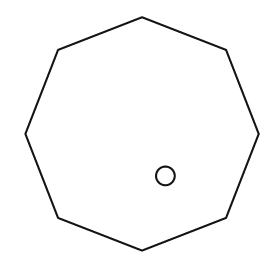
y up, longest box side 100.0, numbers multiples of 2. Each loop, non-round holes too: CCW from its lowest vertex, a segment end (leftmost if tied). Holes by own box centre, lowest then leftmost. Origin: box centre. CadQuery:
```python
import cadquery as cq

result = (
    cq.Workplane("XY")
    .moveTo(0.0, -50.0)
    .lineTo(36.0, -36.0)
    .lineTo(50.0, 0.0)
    .lineTo(36.0, 36.0)
    .lineTo(0.0, 50.0)
    .lineTo(-36.0, 36.0)
    .lineTo(-50.0, 0.0)
    .lineTo(-36.0, -36.0)
    .close()
    .moveTo(10.0, -18.0)
    .circle(4.0)
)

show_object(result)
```